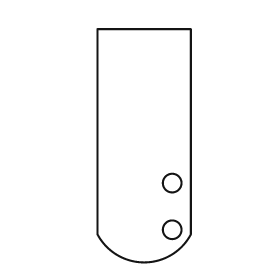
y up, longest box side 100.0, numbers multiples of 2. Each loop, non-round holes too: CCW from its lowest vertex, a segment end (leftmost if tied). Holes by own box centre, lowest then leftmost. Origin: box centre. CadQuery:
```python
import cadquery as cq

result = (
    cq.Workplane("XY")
    .moveTo(-20.0, -38.0)
    .threePointArc((0.0, -50.0), (20.0, -38.0))
    .lineTo(20.0, 50.0)
    .lineTo(-20.0, 50.0)
    .close()
    .moveTo(12.0, -36.0)
    .circle(4.0)
    .moveTo(12.0, -16.0)
    .circle(4.0)
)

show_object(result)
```